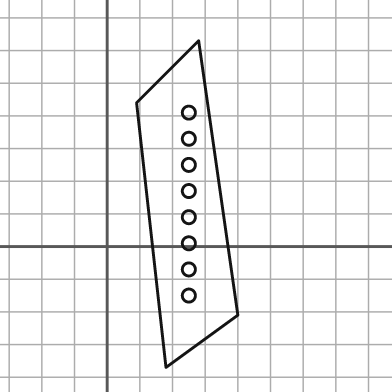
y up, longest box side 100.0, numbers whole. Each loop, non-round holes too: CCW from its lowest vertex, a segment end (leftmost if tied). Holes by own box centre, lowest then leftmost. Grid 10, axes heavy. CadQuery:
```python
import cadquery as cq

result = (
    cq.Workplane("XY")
    .moveTo(18.0, -37.0)
    .lineTo(40.0, -21.0)
    .lineTo(28.0, 63.0)
    .lineTo(9.0, 44.0)
    .close()
    .moveTo(25.0, -15.0)
    .circle(2.0)
    .moveTo(25.0, -7.0)
    .circle(2.0)
    .moveTo(25.0, 1.0)
    .circle(2.0)
    .moveTo(25.0, 9.0)
    .circle(2.0)
    .moveTo(25.0, 17.0)
    .circle(2.0)
    .moveTo(25.0, 25.0)
    .circle(2.0)
    .moveTo(25.0, 33.0)
    .circle(2.0)
    .moveTo(25.0, 41.0)
    .circle(2.0)
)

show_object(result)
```